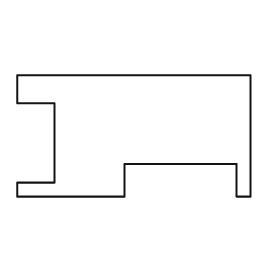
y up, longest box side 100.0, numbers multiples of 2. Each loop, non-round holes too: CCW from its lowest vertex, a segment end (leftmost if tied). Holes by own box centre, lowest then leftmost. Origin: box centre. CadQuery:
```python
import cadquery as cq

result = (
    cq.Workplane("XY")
    .moveTo(-50.0, -26.0)
    .lineTo(-4.0, -26.0)
    .lineTo(-4.0, -12.0)
    .lineTo(44.0, -12.0)
    .lineTo(44.0, -26.0)
    .lineTo(50.0, -26.0)
    .lineTo(50.0, 26.0)
    .lineTo(-50.0, 26.0)
    .lineTo(-50.0, 14.0)
    .lineTo(-34.0, 14.0)
    .lineTo(-34.0, -20.0)
    .lineTo(-50.0, -20.0)
    .close()
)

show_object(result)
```